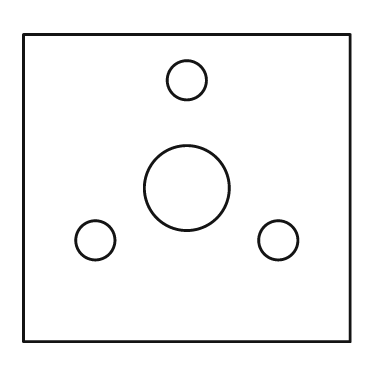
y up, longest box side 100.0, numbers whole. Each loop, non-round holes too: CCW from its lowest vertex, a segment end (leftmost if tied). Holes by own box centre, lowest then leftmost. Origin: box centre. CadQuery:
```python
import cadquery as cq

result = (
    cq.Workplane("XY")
    .moveTo(-50.0, -47.0)
    .lineTo(50.0, -47.0)
    .lineTo(50.0, 47.0)
    .lineTo(-50.0, 47.0)
    .close()
    .moveTo(-28.0, -16.0)
    .circle(6.0)
    .moveTo(28.0, -16.0)
    .circle(6.0)
    .moveTo(0.0, 0.0)
    .circle(13.0)
    .moveTo(0.0, 33.0)
    .circle(6.0)
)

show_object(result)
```